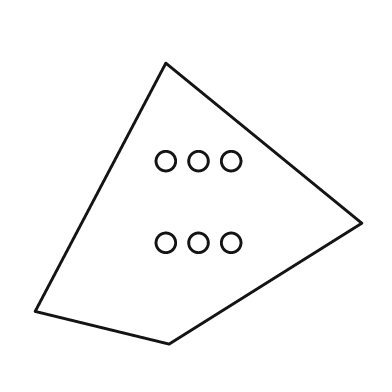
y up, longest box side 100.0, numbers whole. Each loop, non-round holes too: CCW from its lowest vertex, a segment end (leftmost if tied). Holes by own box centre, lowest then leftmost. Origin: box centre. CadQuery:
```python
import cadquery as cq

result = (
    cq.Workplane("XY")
    .moveTo(-9.0, -43.0)
    .lineTo(50.0, -6.0)
    .lineTo(-10.0, 43.0)
    .lineTo(-50.0, -33.0)
    .close()
    .moveTo(-10.0, -12.0)
    .circle(3.0)
    .moveTo(0.0, -12.0)
    .circle(3.0)
    .moveTo(10.0, -12.0)
    .circle(3.0)
    .moveTo(-10.0, 13.0)
    .circle(3.0)
    .moveTo(0.0, 13.0)
    .circle(3.0)
    .moveTo(10.0, 13.0)
    .circle(3.0)
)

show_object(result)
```